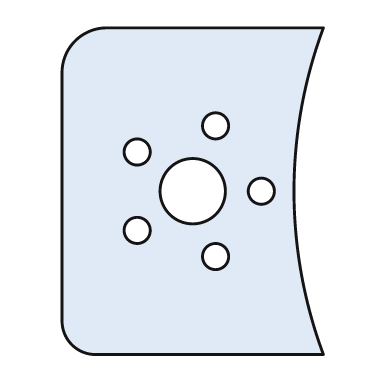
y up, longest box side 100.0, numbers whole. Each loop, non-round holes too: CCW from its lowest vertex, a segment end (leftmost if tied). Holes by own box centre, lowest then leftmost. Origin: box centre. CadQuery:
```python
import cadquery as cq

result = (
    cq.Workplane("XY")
    .moveTo(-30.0, -50.0)
    .lineTo(40.0, -50.0)
    .threePointArc((31.0, 0.0), (40.0, 50.0))
    .lineTo(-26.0, 50.0)
    .threePointArc((-36.0, 46.0), (-40.0, 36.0))
    .lineTo(-40.0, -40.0)
    .threePointArc((-37.0, -47.0), (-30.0, -50.0))
    .close()
    .moveTo(7.0, -20.0)
    .circle(4.0)
    .moveTo(-17.0, -12.0)
    .circle(4.0)
    .moveTo(0.0, 0.0)
    .circle(10.0)
    .moveTo(21.0, 0.0)
    .circle(4.0)
    .moveTo(-17.0, 12.0)
    .circle(4.0)
    .moveTo(7.0, 20.0)
    .circle(4.0)
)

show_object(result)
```